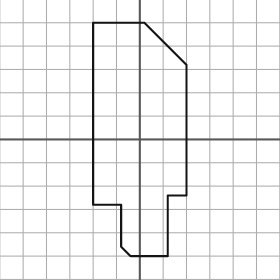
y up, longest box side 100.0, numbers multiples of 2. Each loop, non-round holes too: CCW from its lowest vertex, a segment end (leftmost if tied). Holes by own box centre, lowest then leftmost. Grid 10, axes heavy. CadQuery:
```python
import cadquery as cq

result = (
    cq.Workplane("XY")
    .moveTo(-4.0, -50.0)
    .lineTo(12.0, -50.0)
    .lineTo(12.0, -24.0)
    .lineTo(20.0, -24.0)
    .lineTo(20.0, 32.0)
    .lineTo(2.0, 50.0)
    .lineTo(-20.0, 50.0)
    .lineTo(-20.0, -28.0)
    .lineTo(-8.0, -28.0)
    .lineTo(-8.0, -46.0)
    .close()
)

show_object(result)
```